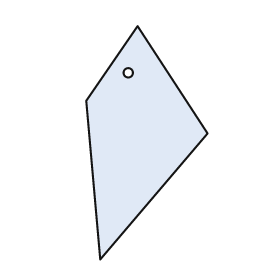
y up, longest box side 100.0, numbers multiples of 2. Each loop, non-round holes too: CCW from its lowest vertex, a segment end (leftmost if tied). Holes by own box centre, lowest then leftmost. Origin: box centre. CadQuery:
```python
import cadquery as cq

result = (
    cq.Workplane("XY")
    .moveTo(-20.0, -50.0)
    .lineTo(26.0, 4.0)
    .lineTo(-4.0, 50.0)
    .lineTo(-26.0, 18.0)
    .close()
    .moveTo(-8.0, 30.0)
    .circle(2.0)
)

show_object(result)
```